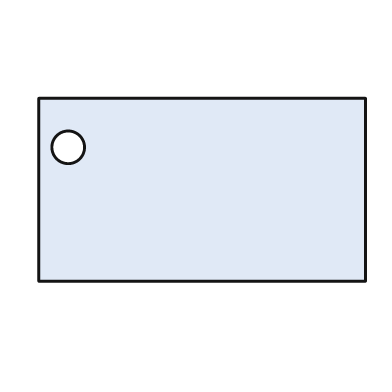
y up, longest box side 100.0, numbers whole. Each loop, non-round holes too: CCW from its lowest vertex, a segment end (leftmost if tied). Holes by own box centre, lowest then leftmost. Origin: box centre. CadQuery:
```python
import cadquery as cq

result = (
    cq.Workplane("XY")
    .moveTo(-50.0, -28.0)
    .lineTo(50.0, -28.0)
    .lineTo(50.0, 28.0)
    .lineTo(-50.0, 28.0)
    .close()
    .moveTo(-41.0, 13.0)
    .circle(5.0)
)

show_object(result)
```